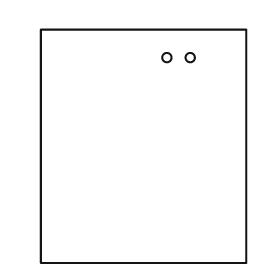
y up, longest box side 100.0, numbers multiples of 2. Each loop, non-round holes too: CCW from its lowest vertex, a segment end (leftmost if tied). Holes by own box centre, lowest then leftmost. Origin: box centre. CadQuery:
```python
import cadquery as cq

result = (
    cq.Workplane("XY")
    .moveTo(-44.0, -50.0)
    .lineTo(44.0, -50.0)
    .lineTo(44.0, 50.0)
    .lineTo(-44.0, 50.0)
    .close()
    .moveTo(10.0, 38.0)
    .circle(2.0)
    .moveTo(20.0, 38.0)
    .circle(2.0)
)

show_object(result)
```